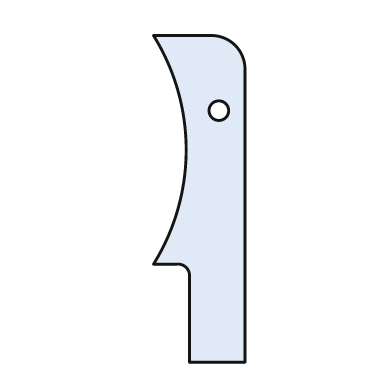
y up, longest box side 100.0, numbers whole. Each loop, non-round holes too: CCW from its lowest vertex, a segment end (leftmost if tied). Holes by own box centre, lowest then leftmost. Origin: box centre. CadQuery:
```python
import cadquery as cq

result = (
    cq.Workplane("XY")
    .moveTo(-3.0, -50.0)
    .lineTo(14.0, -50.0)
    .lineTo(14.0, 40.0)
    .threePointArc((11.0, 47.0), (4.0, 50.0))
    .lineTo(-14.0, 50.0)
    .threePointArc((-4.0, 15.0), (-14.0, -20.0))
    .lineTo(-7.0, -20.0)
    .threePointArc((-4.0, -21.0), (-3.0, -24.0))
    .close()
    .moveTo(6.0, 27.0)
    .circle(3.0)
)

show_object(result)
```